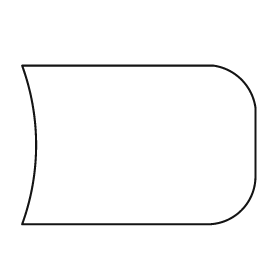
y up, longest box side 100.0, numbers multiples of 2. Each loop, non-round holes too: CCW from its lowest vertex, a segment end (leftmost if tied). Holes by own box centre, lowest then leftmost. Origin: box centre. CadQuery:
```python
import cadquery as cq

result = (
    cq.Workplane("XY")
    .moveTo(-50.0, -34.0)
    .lineTo(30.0, -34.0)
    .threePointArc((44.0, -28.0), (50.0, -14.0))
    .lineTo(50.0, 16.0)
    .threePointArc((44.0, 28.0), (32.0, 34.0))
    .lineTo(-50.0, 34.0)
    .threePointArc((-44.0, 0.0), (-50.0, -34.0))
    .close()
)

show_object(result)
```